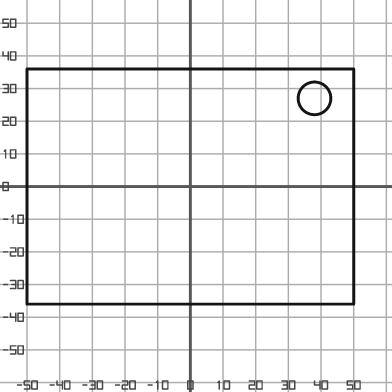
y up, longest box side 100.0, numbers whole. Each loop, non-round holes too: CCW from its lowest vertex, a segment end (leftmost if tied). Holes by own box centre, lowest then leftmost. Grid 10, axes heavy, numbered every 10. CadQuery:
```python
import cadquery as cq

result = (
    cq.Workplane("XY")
    .moveTo(-50.0, -36.0)
    .lineTo(50.0, -36.0)
    .lineTo(50.0, 36.0)
    .lineTo(-50.0, 36.0)
    .close()
    .moveTo(38.0, 27.0)
    .circle(5.0)
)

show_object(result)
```